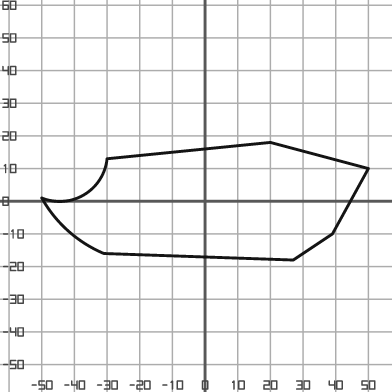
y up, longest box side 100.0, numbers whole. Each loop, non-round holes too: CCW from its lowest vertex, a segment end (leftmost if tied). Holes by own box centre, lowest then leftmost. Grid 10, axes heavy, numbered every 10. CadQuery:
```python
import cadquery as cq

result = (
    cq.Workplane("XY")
    .moveTo(27.0, -18.0)
    .lineTo(39.0, -10.0)
    .lineTo(50.0, 10.0)
    .lineTo(20.0, 18.0)
    .lineTo(-30.0, 13.0)
    .threePointArc((-37.0, 2.0), (-50.0, 1.0))
    .threePointArc((-42.0, -9.0), (-31.0, -16.0))
    .close()
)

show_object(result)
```